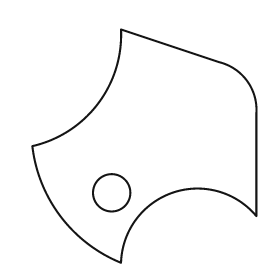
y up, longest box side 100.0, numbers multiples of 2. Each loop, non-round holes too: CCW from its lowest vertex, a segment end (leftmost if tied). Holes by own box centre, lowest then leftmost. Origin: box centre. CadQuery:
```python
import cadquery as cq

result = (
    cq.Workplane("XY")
    .moveTo(-10.0, -50.0)
    .threePointArc((12.0, -20.0), (48.0, -30.0))
    .lineTo(48.0, 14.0)
    .threePointArc((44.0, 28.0), (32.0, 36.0))
    .lineTo(-10.0, 50.0)
    .threePointArc((-20.0, 18.0), (-48.0, 0.0))
    .threePointArc((-36.0, -30.0), (-10.0, -50.0))
    .close()
    .moveTo(-14.0, -20.0)
    .circle(8.0)
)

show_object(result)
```